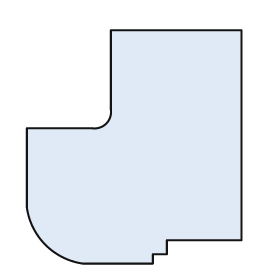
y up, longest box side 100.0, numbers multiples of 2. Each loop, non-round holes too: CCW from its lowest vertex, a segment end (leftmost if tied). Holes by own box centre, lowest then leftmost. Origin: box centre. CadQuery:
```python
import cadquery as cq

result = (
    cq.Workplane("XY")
    .moveTo(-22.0, -50.0)
    .lineTo(8.0, -50.0)
    .lineTo(8.0, -46.0)
    .lineTo(14.0, -46.0)
    .lineTo(14.0, -40.0)
    .lineTo(46.0, -40.0)
    .lineTo(46.0, 50.0)
    .lineTo(-10.0, 50.0)
    .lineTo(-10.0, 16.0)
    .threePointArc((-12.0, 10.0), (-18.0, 8.0))
    .lineTo(-46.0, 8.0)
    .lineTo(-46.0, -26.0)
    .threePointArc((-38.0, -42.0), (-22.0, -50.0))
    .close()
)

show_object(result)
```